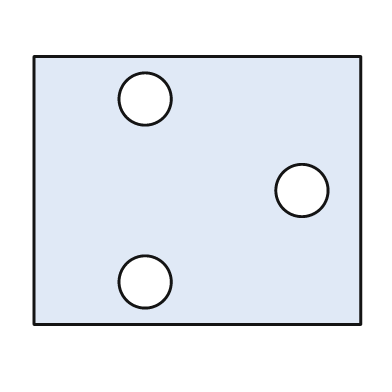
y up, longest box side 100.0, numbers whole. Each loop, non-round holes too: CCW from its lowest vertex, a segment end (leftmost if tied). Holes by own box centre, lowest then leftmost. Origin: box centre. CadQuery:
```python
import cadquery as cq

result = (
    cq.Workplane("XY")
    .moveTo(-50.0, -41.0)
    .lineTo(50.0, -41.0)
    .lineTo(50.0, 41.0)
    .lineTo(-50.0, 41.0)
    .close()
    .moveTo(-16.0, -28.0)
    .circle(8.0)
    .moveTo(32.0, 0.0)
    .circle(8.0)
    .moveTo(-16.0, 28.0)
    .circle(8.0)
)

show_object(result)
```